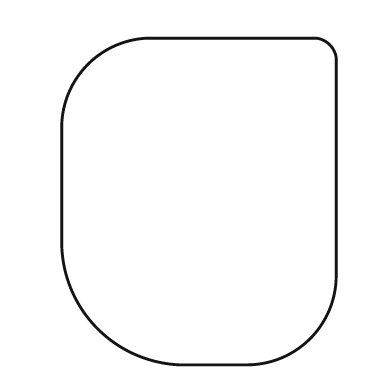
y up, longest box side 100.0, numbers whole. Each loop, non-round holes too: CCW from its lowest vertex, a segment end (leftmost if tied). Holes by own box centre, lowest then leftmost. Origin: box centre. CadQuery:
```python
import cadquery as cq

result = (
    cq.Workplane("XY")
    .moveTo(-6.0, -50.0)
    .lineTo(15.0, -50.0)
    .threePointArc((34.0, -42.0), (42.0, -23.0))
    .lineTo(42.0, 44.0)
    .threePointArc((40.0, 48.0), (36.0, 50.0))
    .lineTo(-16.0, 50.0)
    .threePointArc((-34.0, 42.0), (-42.0, 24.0))
    .lineTo(-42.0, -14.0)
    .threePointArc((-31.0, -39.0), (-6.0, -50.0))
    .close()
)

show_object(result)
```